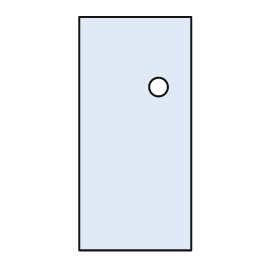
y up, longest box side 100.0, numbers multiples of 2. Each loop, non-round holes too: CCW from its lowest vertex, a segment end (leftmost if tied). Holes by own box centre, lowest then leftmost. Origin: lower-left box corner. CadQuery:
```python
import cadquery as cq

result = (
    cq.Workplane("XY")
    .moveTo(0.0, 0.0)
    .lineTo(48.0, 0.0)
    .lineTo(48.0, 100.0)
    .lineTo(0.0, 100.0)
    .close()
    .moveTo(34.0, 70.0)
    .circle(4.0)
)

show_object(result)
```